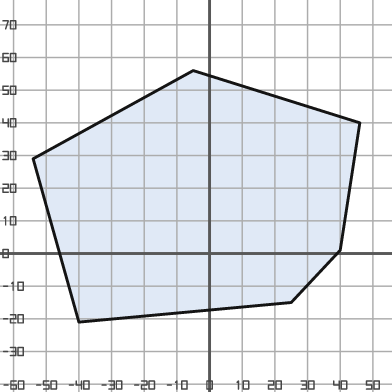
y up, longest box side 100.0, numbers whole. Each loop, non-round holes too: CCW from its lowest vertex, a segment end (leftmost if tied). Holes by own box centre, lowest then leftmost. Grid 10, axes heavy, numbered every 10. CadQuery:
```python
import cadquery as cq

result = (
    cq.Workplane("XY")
    .moveTo(-40.0, -21.0)
    .lineTo(25.0, -15.0)
    .lineTo(40.0, 1.0)
    .lineTo(46.0, 40.0)
    .lineTo(-5.0, 56.0)
    .lineTo(-54.0, 29.0)
    .close()
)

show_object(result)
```